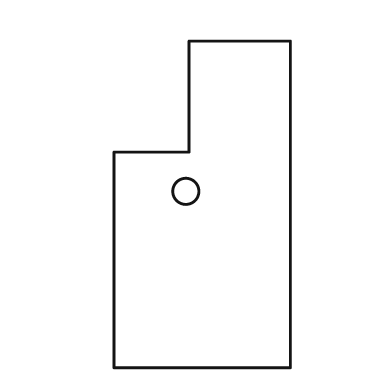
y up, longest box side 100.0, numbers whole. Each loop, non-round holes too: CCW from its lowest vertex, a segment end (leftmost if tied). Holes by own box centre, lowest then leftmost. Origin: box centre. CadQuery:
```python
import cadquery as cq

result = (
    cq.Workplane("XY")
    .moveTo(-27.0, -50.0)
    .lineTo(27.0, -50.0)
    .lineTo(27.0, 50.0)
    .lineTo(-4.0, 50.0)
    .lineTo(-4.0, 16.0)
    .lineTo(-27.0, 16.0)
    .close()
    .moveTo(-5.0, 4.0)
    .circle(4.0)
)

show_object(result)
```